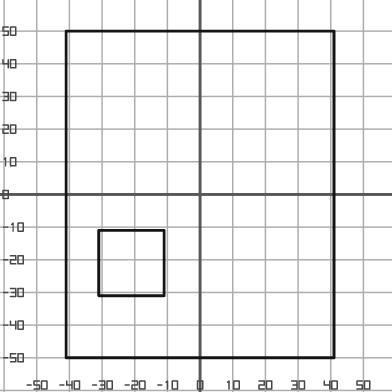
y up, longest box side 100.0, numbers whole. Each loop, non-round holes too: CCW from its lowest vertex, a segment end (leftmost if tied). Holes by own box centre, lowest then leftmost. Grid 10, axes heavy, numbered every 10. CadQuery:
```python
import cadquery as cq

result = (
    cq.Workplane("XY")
    .moveTo(-41.0, -50.0)
    .lineTo(41.0, -50.0)
    .lineTo(41.0, 50.0)
    .lineTo(-41.0, 50.0)
    .close()
    .moveTo(-31.0, -31.0)
    .lineTo(-11.0, -31.0)
    .lineTo(-11.0, -11.0)
    .lineTo(-31.0, -11.0)
    .close()
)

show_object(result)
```